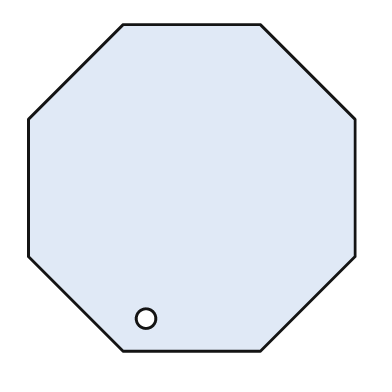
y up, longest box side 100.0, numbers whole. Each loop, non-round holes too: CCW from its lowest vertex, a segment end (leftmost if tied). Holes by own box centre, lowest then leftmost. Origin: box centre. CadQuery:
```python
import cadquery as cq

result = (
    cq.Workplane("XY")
    .moveTo(-21.0, -50.0)
    .lineTo(21.0, -50.0)
    .lineTo(50.0, -21.0)
    .lineTo(50.0, 21.0)
    .lineTo(21.0, 50.0)
    .lineTo(-21.0, 50.0)
    .lineTo(-50.0, 21.0)
    .lineTo(-50.0, -21.0)
    .close()
    .moveTo(-14.0, -40.0)
    .circle(3.0)
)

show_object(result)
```